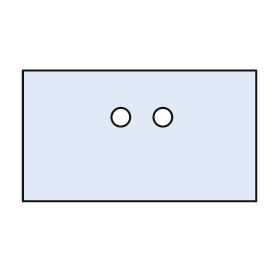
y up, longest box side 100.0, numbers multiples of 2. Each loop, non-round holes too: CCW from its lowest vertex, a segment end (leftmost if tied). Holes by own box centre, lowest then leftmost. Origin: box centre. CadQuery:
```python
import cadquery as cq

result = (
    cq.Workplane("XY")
    .moveTo(-50.0, -28.0)
    .lineTo(50.0, -28.0)
    .lineTo(50.0, 28.0)
    .lineTo(-50.0, 28.0)
    .close()
    .moveTo(-8.0, 8.0)
    .circle(4.0)
    .moveTo(10.0, 8.0)
    .circle(4.0)
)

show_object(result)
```